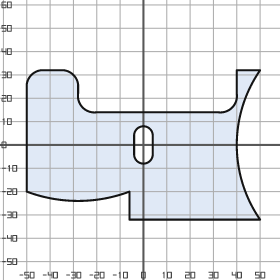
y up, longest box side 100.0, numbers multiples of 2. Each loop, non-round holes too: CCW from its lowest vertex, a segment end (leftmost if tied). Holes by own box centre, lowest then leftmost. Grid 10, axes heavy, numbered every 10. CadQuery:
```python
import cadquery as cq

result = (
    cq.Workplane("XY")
    .moveTo(-6.0, -32.0)
    .lineTo(50.0, -32.0)
    .threePointArc((40.0, 0.0), (50.0, 32.0))
    .lineTo(40.0, 32.0)
    .lineTo(40.0, 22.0)
    .threePointArc((38.0, 16.0), (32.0, 14.0))
    .lineTo(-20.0, 14.0)
    .threePointArc((-26.0, 16.0), (-28.0, 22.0))
    .lineTo(-28.0, 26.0)
    .threePointArc((-30.0, 30.0), (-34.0, 32.0))
    .lineTo(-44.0, 32.0)
    .threePointArc((-48.0, 30.0), (-50.0, 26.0))
    .lineTo(-50.0, -20.0)
    .threePointArc((-28.0, -24.0), (-6.0, -20.0))
    .close()
    .moveTo(-4.0, -4.0)
    .threePointArc((0.0, -8.0), (4.0, -4.0))
    .lineTo(4.0, 4.0)
    .threePointArc((0.0, 8.0), (-4.0, 4.0))
    .close()
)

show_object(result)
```